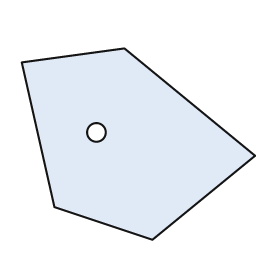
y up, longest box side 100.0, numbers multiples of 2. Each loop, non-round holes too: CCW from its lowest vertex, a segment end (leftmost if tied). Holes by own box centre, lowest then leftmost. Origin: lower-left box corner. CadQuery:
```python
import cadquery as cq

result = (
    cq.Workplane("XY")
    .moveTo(56.0, 0.0)
    .lineTo(100.0, 36.0)
    .lineTo(44.0, 82.0)
    .lineTo(0.0, 76.0)
    .lineTo(14.0, 14.0)
    .close()
    .moveTo(32.0, 46.0)
    .circle(4.0)
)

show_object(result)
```